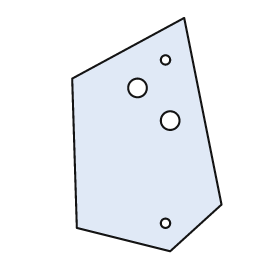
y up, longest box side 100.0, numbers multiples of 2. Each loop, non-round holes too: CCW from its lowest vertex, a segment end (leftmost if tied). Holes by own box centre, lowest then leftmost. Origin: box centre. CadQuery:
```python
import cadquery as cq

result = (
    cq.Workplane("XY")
    .moveTo(10.0, -50.0)
    .lineTo(32.0, -30.0)
    .lineTo(16.0, 50.0)
    .lineTo(-32.0, 24.0)
    .lineTo(-30.0, -40.0)
    .close()
    .moveTo(8.0, -38.0)
    .circle(2.0)
    .moveTo(10.0, 6.0)
    .circle(4.0)
    .moveTo(-4.0, 20.0)
    .circle(4.0)
    .moveTo(8.0, 32.0)
    .circle(2.0)
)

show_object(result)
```